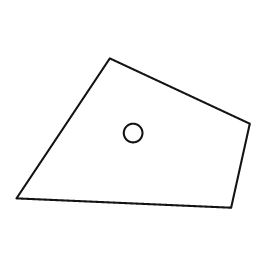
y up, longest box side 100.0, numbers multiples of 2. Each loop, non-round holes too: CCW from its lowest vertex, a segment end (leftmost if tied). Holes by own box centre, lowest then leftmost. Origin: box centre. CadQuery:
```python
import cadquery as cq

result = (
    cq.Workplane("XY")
    .moveTo(42.0, -32.0)
    .lineTo(50.0, 4.0)
    .lineTo(-10.0, 32.0)
    .lineTo(-50.0, -28.0)
    .close()
    .moveTo(0.0, 0.0)
    .circle(4.0)
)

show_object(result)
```